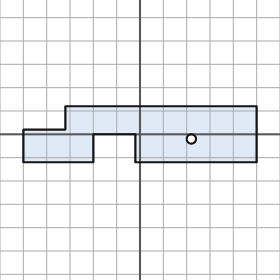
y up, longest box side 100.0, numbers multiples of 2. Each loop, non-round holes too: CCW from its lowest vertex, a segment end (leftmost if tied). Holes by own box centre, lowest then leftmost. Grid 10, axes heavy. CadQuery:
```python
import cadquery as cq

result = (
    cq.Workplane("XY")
    .moveTo(-50.0, -12.0)
    .lineTo(-20.0, -12.0)
    .lineTo(-20.0, 0.0)
    .lineTo(-2.0, 0.0)
    .lineTo(-2.0, -12.0)
    .lineTo(50.0, -12.0)
    .lineTo(50.0, 12.0)
    .lineTo(-32.0, 12.0)
    .lineTo(-32.0, 2.0)
    .lineTo(-50.0, 2.0)
    .close()
    .moveTo(22.0, -2.0)
    .circle(2.0)
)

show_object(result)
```